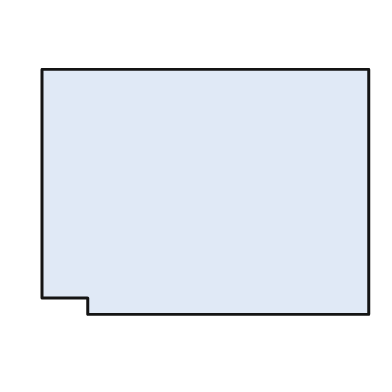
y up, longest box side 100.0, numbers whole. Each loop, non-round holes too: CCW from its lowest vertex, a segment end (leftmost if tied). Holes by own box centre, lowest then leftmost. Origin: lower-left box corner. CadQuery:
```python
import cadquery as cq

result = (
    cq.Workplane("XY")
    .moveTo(14.0, 0.0)
    .lineTo(100.0, 0.0)
    .lineTo(100.0, 75.0)
    .lineTo(0.0, 75.0)
    .lineTo(0.0, 5.0)
    .lineTo(14.0, 5.0)
    .close()
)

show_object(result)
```